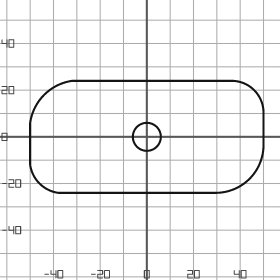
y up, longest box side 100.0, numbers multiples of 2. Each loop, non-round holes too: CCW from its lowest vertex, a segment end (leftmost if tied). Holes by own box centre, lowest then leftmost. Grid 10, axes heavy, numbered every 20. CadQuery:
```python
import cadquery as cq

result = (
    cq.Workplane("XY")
    .moveTo(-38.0, -24.0)
    .lineTo(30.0, -24.0)
    .threePointArc((44.0, -18.0), (50.0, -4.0))
    .lineTo(50.0, 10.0)
    .threePointArc((46.0, 20.0), (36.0, 24.0))
    .lineTo(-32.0, 24.0)
    .threePointArc((-44.0, 18.0), (-50.0, 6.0))
    .lineTo(-50.0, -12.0)
    .threePointArc((-46.0, -20.0), (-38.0, -24.0))
    .close()
    .moveTo(0.0, 0.0)
    .circle(6.0)
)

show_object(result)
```